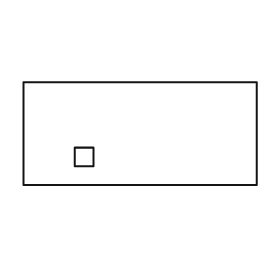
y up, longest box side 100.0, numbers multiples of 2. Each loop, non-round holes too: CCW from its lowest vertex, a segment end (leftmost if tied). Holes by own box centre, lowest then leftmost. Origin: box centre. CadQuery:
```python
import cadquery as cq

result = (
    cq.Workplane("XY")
    .moveTo(-50.0, -22.0)
    .lineTo(50.0, -22.0)
    .lineTo(50.0, 22.0)
    .lineTo(-50.0, 22.0)
    .close()
    .moveTo(-28.0, -14.0)
    .lineTo(-20.0, -14.0)
    .lineTo(-20.0, -6.0)
    .lineTo(-28.0, -6.0)
    .close()
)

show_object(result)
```